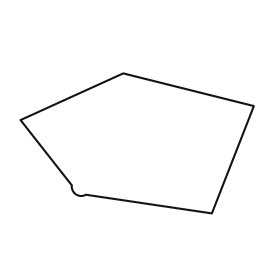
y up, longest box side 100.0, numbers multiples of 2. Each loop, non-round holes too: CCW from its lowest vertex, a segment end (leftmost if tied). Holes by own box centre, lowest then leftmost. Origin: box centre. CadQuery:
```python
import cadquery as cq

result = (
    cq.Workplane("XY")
    .moveTo(32.0, -30.0)
    .lineTo(50.0, 16.0)
    .lineTo(-6.0, 30.0)
    .lineTo(-50.0, 10.0)
    .lineTo(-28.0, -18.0)
    .threePointArc((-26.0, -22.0), (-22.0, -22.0))
    .close()
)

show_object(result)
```